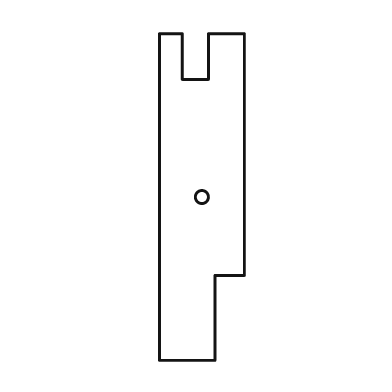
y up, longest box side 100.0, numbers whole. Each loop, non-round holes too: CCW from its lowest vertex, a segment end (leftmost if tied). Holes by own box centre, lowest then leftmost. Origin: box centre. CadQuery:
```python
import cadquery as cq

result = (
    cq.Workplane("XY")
    .moveTo(-13.0, -50.0)
    .lineTo(4.0, -50.0)
    .lineTo(4.0, -24.0)
    .lineTo(13.0, -24.0)
    .lineTo(13.0, 50.0)
    .lineTo(2.0, 50.0)
    .lineTo(2.0, 36.0)
    .lineTo(-6.0, 36.0)
    .lineTo(-6.0, 50.0)
    .lineTo(-13.0, 50.0)
    .close()
    .moveTo(0.0, 0.0)
    .circle(2.0)
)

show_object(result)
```